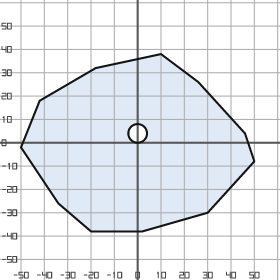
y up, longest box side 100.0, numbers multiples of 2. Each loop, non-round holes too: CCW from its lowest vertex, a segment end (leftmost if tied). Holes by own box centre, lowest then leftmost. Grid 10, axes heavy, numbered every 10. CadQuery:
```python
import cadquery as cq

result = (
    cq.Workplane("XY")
    .moveTo(-20.0, -38.0)
    .lineTo(2.0, -38.0)
    .lineTo(30.0, -30.0)
    .lineTo(50.0, -8.0)
    .lineTo(46.0, 4.0)
    .lineTo(26.0, 26.0)
    .lineTo(10.0, 38.0)
    .lineTo(-18.0, 32.0)
    .lineTo(-42.0, 18.0)
    .lineTo(-50.0, -2.0)
    .lineTo(-34.0, -26.0)
    .close()
    .moveTo(0.0, 4.0)
    .circle(4.0)
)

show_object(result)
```